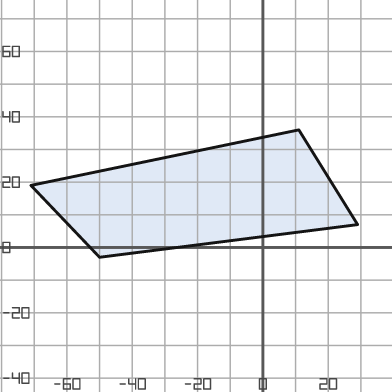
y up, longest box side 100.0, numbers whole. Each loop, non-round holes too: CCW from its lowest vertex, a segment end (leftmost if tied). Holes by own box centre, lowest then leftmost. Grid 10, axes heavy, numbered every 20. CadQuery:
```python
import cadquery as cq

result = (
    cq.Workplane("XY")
    .moveTo(-50.0, -3.0)
    .lineTo(29.0, 7.0)
    .lineTo(11.0, 36.0)
    .lineTo(-71.0, 19.0)
    .close()
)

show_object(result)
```